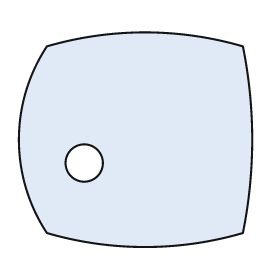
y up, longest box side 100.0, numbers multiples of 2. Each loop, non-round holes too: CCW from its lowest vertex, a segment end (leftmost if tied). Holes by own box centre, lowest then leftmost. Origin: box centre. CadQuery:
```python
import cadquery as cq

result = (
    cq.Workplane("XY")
    .moveTo(-38.0, -40.0)
    .threePointArc((4.0, -46.0), (46.0, -40.0))
    .threePointArc((50.0, 0.0), (46.0, 40.0))
    .threePointArc((4.0, 46.0), (-38.0, 40.0))
    .threePointArc((-50.0, 0.0), (-38.0, -40.0))
    .close()
    .moveTo(-22.0, -10.0)
    .circle(8.0)
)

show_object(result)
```